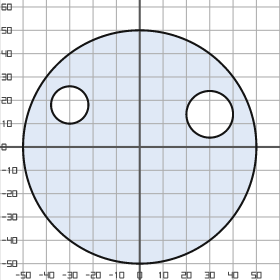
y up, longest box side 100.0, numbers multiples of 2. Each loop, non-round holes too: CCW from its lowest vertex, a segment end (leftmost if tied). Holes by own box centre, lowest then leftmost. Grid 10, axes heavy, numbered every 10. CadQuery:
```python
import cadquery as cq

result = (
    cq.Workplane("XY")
    .moveTo(0.0, 0.0)
    .circle(50.0)
    .moveTo(30.0, 14.0)
    .circle(10.0)
    .moveTo(-30.0, 18.0)
    .circle(8.0)
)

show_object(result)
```